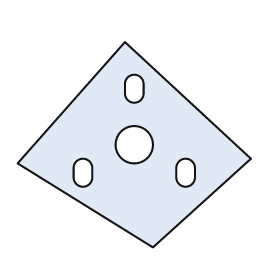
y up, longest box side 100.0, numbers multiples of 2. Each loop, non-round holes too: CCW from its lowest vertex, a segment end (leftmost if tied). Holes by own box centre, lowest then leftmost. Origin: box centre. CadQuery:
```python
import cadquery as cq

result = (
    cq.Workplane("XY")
    .moveTo(8.0, -44.0)
    .lineTo(50.0, -6.0)
    .lineTo(-4.0, 44.0)
    .lineTo(-50.0, -8.0)
    .close()
    .moveTo(-26.0, -14.0)
    .threePointArc((-22.0, -18.0), (-18.0, -14.0))
    .lineTo(-18.0, -10.0)
    .threePointArc((-22.0, -6.0), (-26.0, -10.0))
    .close()
    .moveTo(18.0, -14.0)
    .threePointArc((22.0, -18.0), (26.0, -14.0))
    .lineTo(26.0, -10.0)
    .threePointArc((22.0, -6.0), (18.0, -10.0))
    .close()
    .moveTo(0.0, 0.0)
    .circle(8.0)
    .moveTo(-4.0, 22.0)
    .threePointArc((0.0, 18.0), (4.0, 22.0))
    .lineTo(4.0, 26.0)
    .threePointArc((0.0, 30.0), (-4.0, 26.0))
    .close()
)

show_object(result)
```